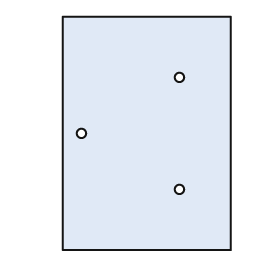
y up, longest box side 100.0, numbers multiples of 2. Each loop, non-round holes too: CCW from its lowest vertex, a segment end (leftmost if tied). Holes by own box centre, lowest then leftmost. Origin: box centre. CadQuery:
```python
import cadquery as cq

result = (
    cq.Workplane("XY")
    .moveTo(-36.0, -50.0)
    .lineTo(36.0, -50.0)
    .lineTo(36.0, 50.0)
    .lineTo(-36.0, 50.0)
    .close()
    .moveTo(14.0, -24.0)
    .circle(2.0)
    .moveTo(-28.0, 0.0)
    .circle(2.0)
    .moveTo(14.0, 24.0)
    .circle(2.0)
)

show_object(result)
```